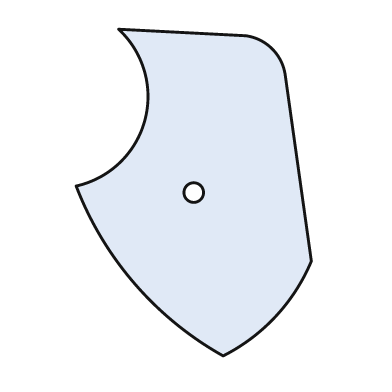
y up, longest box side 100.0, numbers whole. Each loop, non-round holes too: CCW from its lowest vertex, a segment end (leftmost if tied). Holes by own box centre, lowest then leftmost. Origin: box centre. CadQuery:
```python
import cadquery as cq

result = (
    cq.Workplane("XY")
    .moveTo(9.0, -50.0)
    .threePointArc((25.0, -38.0), (36.0, -21.0))
    .lineTo(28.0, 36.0)
    .threePointArc((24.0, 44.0), (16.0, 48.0))
    .lineTo(-23.0, 50.0)
    .threePointArc((-15.0, 22.0), (-36.0, 2.0))
    .threePointArc((-18.0, -28.0), (9.0, -50.0))
    .close()
    .moveTo(0.0, 0.0)
    .circle(3.0)
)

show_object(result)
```